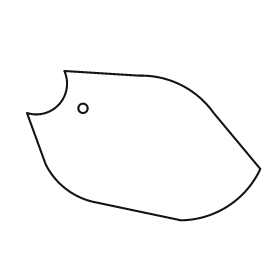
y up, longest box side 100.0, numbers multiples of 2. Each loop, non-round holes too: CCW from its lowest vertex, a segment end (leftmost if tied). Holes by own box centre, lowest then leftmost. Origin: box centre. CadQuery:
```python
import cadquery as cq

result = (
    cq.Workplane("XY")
    .moveTo(16.0, -32.0)
    .threePointArc((36.0, -26.0), (50.0, -10.0))
    .lineTo(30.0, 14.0)
    .threePointArc((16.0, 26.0), (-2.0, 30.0))
    .lineTo(-34.0, 32.0)
    .threePointArc((-36.0, 18.0), (-50.0, 14.0))
    .lineTo(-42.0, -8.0)
    .threePointArc((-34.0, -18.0), (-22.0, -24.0))
    .close()
    .moveTo(-26.0, 16.0)
    .circle(2.0)
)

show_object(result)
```